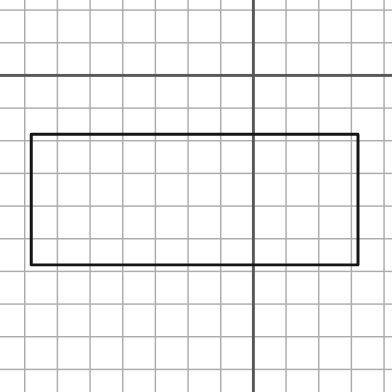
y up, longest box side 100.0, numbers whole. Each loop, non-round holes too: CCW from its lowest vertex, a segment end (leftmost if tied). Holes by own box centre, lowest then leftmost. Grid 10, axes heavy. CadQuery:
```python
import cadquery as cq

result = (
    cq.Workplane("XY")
    .moveTo(-68.0, -58.0)
    .lineTo(32.0, -58.0)
    .lineTo(32.0, -18.0)
    .lineTo(-68.0, -18.0)
    .close()
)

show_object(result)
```